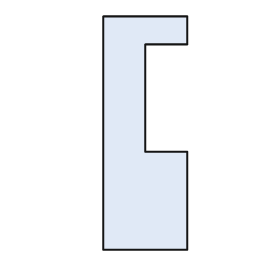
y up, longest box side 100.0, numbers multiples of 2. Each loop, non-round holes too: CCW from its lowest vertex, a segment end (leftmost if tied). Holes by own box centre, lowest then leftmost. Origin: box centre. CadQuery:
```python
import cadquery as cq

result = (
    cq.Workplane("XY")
    .moveTo(-18.0, -50.0)
    .lineTo(18.0, -50.0)
    .lineTo(18.0, -8.0)
    .lineTo(0.0, -8.0)
    .lineTo(0.0, 38.0)
    .lineTo(18.0, 38.0)
    .lineTo(18.0, 50.0)
    .lineTo(-18.0, 50.0)
    .close()
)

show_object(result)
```